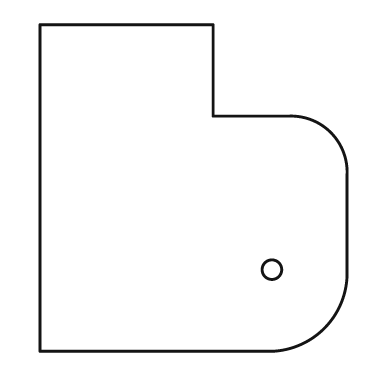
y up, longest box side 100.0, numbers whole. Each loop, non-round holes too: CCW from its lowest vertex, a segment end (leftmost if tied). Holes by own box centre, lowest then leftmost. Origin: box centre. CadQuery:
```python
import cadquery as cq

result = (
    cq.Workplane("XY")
    .moveTo(-47.0, -50.0)
    .lineTo(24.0, -50.0)
    .threePointArc((40.0, -43.0), (47.0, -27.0))
    .lineTo(47.0, 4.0)
    .threePointArc((42.0, 17.0), (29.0, 22.0))
    .lineTo(6.0, 22.0)
    .lineTo(6.0, 50.0)
    .lineTo(-47.0, 50.0)
    .close()
    .moveTo(24.0, -25.0)
    .circle(3.0)
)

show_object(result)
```